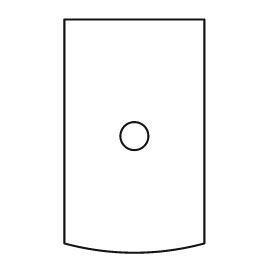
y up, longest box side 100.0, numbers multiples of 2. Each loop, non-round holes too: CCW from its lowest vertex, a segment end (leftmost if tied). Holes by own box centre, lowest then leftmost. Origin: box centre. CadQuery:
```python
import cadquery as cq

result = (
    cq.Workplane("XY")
    .moveTo(-30.0, -46.0)
    .threePointArc((0.0, -50.0), (30.0, -46.0))
    .lineTo(30.0, 50.0)
    .lineTo(-30.0, 50.0)
    .close()
    .moveTo(0.0, 0.0)
    .circle(6.0)
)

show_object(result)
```